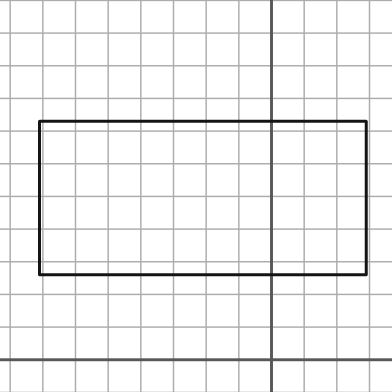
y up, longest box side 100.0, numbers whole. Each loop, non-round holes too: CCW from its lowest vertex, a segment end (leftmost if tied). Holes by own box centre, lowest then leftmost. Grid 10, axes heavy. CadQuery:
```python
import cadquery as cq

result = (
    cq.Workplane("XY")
    .moveTo(-71.0, 26.0)
    .lineTo(29.0, 26.0)
    .lineTo(29.0, 73.0)
    .lineTo(-71.0, 73.0)
    .close()
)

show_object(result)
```